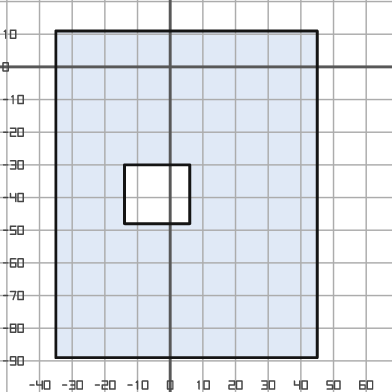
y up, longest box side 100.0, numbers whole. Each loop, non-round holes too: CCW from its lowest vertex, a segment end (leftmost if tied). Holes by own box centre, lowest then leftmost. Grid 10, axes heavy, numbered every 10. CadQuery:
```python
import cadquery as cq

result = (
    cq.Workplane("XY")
    .moveTo(-35.0, -89.0)
    .lineTo(45.0, -89.0)
    .lineTo(45.0, 11.0)
    .lineTo(-35.0, 11.0)
    .close()
    .moveTo(-14.0, -48.0)
    .lineTo(6.0, -48.0)
    .lineTo(6.0, -30.0)
    .lineTo(-14.0, -30.0)
    .close()
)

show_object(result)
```